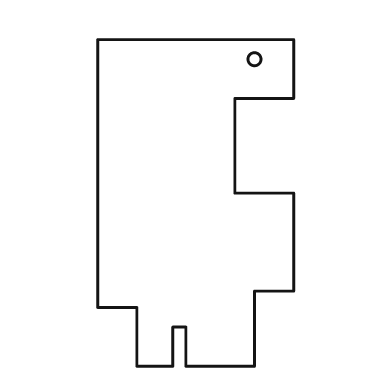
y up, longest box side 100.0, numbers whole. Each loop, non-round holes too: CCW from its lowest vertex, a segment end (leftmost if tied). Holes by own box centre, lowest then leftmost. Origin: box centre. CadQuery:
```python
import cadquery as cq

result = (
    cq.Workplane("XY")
    .moveTo(-18.0, -50.0)
    .lineTo(-7.0, -50.0)
    .lineTo(-7.0, -38.0)
    .lineTo(-3.0, -38.0)
    .lineTo(-3.0, -50.0)
    .lineTo(18.0, -50.0)
    .lineTo(18.0, -27.0)
    .lineTo(30.0, -27.0)
    .lineTo(30.0, 3.0)
    .lineTo(12.0, 3.0)
    .lineTo(12.0, 32.0)
    .lineTo(30.0, 32.0)
    .lineTo(30.0, 50.0)
    .lineTo(-30.0, 50.0)
    .lineTo(-30.0, -32.0)
    .lineTo(-18.0, -32.0)
    .close()
    .moveTo(18.0, 44.0)
    .circle(2.0)
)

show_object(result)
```